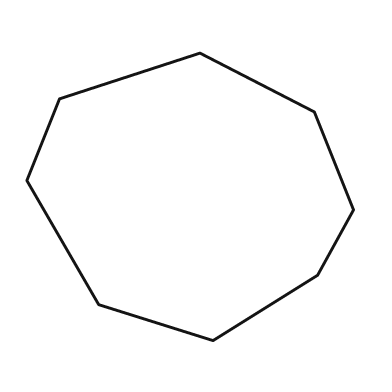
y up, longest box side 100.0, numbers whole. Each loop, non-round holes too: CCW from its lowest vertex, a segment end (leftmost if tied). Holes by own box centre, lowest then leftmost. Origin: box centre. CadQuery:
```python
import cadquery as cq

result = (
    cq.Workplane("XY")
    .moveTo(7.0, -44.0)
    .lineTo(39.0, -24.0)
    .lineTo(50.0, -4.0)
    .lineTo(38.0, 26.0)
    .lineTo(3.0, 44.0)
    .lineTo(-40.0, 30.0)
    .lineTo(-50.0, 5.0)
    .lineTo(-28.0, -33.0)
    .close()
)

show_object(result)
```